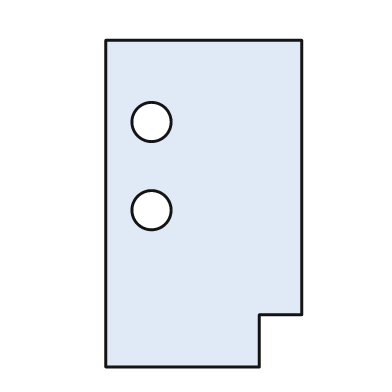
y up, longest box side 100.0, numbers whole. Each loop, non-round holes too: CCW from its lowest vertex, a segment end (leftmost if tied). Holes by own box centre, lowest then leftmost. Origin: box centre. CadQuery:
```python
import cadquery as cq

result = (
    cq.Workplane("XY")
    .moveTo(-30.0, -50.0)
    .lineTo(17.0, -50.0)
    .lineTo(17.0, -34.0)
    .lineTo(30.0, -34.0)
    .lineTo(30.0, 50.0)
    .lineTo(-30.0, 50.0)
    .close()
    .moveTo(-16.0, -2.0)
    .circle(6.0)
    .moveTo(-16.0, 25.0)
    .circle(6.0)
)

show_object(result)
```